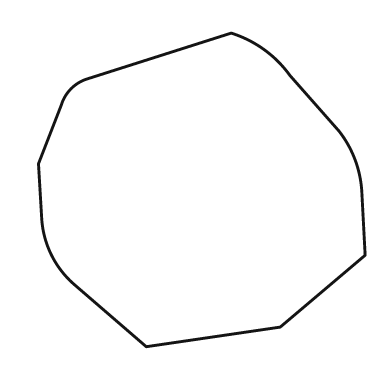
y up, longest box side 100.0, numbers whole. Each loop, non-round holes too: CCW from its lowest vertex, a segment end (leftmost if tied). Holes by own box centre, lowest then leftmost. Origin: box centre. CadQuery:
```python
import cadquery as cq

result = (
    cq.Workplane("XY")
    .moveTo(-17.0, -48.0)
    .lineTo(24.0, -42.0)
    .lineTo(50.0, -20.0)
    .lineTo(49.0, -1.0)
    .threePointArc((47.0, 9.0), (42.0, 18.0))
    .lineTo(27.0, 35.0)
    .threePointArc((19.0, 43.0), (9.0, 48.0))
    .lineTo(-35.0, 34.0)
    .threePointArc((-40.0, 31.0), (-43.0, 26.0))
    .lineTo(-50.0, 8.0)
    .lineTo(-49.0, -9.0)
    .threePointArc((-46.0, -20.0), (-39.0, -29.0))
    .close()
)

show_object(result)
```